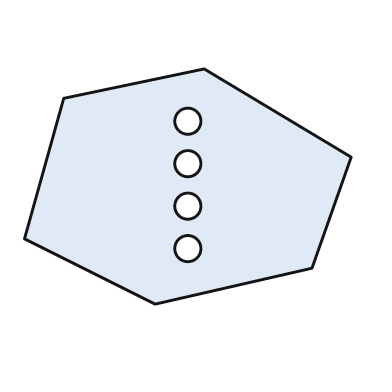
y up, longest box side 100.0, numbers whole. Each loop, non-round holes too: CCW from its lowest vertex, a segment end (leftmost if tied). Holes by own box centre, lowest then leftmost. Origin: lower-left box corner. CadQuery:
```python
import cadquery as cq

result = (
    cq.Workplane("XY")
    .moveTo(40.0, 0.0)
    .lineTo(88.0, 11.0)
    .lineTo(100.0, 45.0)
    .lineTo(55.0, 72.0)
    .lineTo(12.0, 63.0)
    .lineTo(0.0, 20.0)
    .close()
    .moveTo(50.0, 17.0)
    .circle(4.0)
    .moveTo(50.0, 30.0)
    .circle(4.0)
    .moveTo(50.0, 43.0)
    .circle(4.0)
    .moveTo(50.0, 56.0)
    .circle(4.0)
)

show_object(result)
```